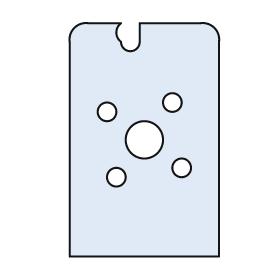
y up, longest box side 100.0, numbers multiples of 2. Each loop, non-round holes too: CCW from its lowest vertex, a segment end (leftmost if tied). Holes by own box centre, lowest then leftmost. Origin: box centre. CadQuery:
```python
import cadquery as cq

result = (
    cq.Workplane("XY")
    .moveTo(-32.0, -50.0)
    .lineTo(32.0, -50.0)
    .lineTo(32.0, 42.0)
    .threePointArc((30.0, 48.0), (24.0, 50.0))
    .lineTo(-2.0, 50.0)
    .lineTo(-2.0, 42.0)
    .threePointArc((-6.0, 38.0), (-10.0, 42.0))
    .threePointArc((-12.0, 46.0), (-10.0, 50.0))
    .lineTo(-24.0, 50.0)
    .threePointArc((-30.0, 48.0), (-32.0, 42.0))
    .close()
    .moveTo(-12.0, -16.0)
    .circle(4.0)
    .moveTo(16.0, -12.0)
    .circle(4.0)
    .moveTo(0.0, 0.0)
    .circle(8.0)
    .moveTo(-16.0, 12.0)
    .circle(4.0)
    .moveTo(12.0, 16.0)
    .circle(4.0)
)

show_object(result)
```